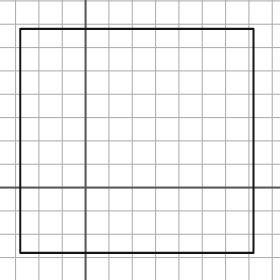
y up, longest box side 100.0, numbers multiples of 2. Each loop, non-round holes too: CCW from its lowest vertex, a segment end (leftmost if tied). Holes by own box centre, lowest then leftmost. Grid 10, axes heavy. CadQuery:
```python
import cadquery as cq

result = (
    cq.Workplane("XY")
    .moveTo(-28.0, -28.0)
    .lineTo(72.0, -28.0)
    .lineTo(72.0, 68.0)
    .lineTo(-28.0, 68.0)
    .close()
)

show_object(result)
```